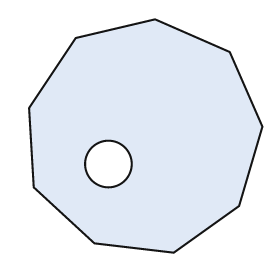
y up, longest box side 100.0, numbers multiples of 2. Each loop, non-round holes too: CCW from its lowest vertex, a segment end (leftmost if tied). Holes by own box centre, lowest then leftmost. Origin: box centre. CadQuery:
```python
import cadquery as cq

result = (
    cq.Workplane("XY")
    .moveTo(12.0, -50.0)
    .lineTo(40.0, -30.0)
    .lineTo(50.0, 4.0)
    .lineTo(36.0, 36.0)
    .lineTo(4.0, 50.0)
    .lineTo(-30.0, 42.0)
    .lineTo(-50.0, 12.0)
    .lineTo(-48.0, -22.0)
    .lineTo(-22.0, -46.0)
    .close()
    .moveTo(-16.0, -12.0)
    .circle(10.0)
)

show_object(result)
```